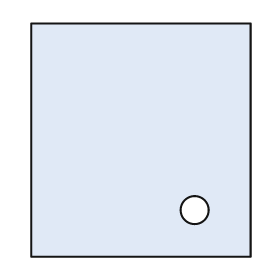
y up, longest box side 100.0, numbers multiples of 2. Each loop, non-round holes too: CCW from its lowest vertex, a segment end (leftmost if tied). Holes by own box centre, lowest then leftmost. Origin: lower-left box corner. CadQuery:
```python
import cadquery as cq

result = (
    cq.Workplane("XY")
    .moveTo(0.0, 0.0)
    .lineTo(94.0, 0.0)
    .lineTo(94.0, 100.0)
    .lineTo(0.0, 100.0)
    .close()
    .moveTo(70.0, 20.0)
    .circle(6.0)
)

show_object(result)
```